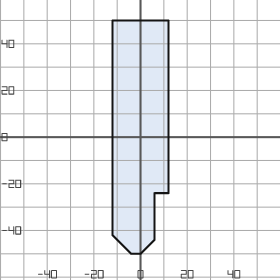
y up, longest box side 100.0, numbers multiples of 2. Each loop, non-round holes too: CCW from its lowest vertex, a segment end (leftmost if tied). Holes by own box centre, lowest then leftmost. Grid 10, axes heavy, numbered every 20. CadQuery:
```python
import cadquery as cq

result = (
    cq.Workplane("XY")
    .moveTo(-4.0, -50.0)
    .lineTo(0.0, -50.0)
    .lineTo(6.0, -44.0)
    .lineTo(6.0, -24.0)
    .lineTo(12.0, -24.0)
    .lineTo(12.0, 50.0)
    .lineTo(-12.0, 50.0)
    .lineTo(-12.0, -42.0)
    .close()
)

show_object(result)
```